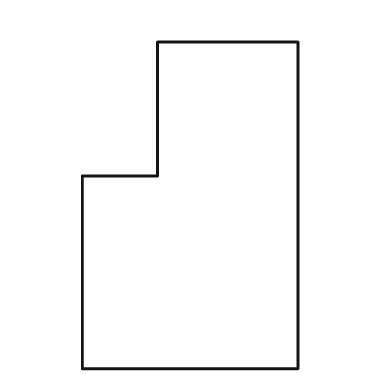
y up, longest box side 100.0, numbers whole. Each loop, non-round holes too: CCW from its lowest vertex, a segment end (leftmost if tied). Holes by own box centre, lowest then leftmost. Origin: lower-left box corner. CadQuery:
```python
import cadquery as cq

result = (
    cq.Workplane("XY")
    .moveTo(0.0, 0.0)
    .lineTo(66.0, 0.0)
    .lineTo(66.0, 100.0)
    .lineTo(23.0, 100.0)
    .lineTo(23.0, 59.0)
    .lineTo(0.0, 59.0)
    .close()
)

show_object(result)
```